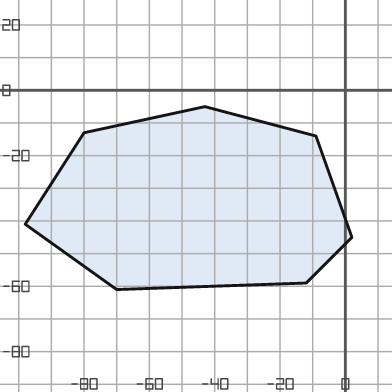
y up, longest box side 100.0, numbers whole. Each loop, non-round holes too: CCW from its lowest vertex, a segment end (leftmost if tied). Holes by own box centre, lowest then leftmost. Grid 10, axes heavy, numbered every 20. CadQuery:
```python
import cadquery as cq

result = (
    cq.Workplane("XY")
    .moveTo(-70.0, -61.0)
    .lineTo(-12.0, -59.0)
    .lineTo(2.0, -45.0)
    .lineTo(-9.0, -14.0)
    .lineTo(-43.0, -5.0)
    .lineTo(-80.0, -13.0)
    .lineTo(-98.0, -41.0)
    .close()
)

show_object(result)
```